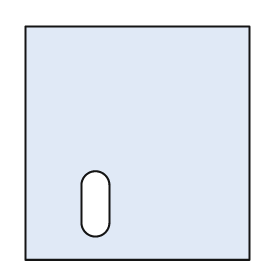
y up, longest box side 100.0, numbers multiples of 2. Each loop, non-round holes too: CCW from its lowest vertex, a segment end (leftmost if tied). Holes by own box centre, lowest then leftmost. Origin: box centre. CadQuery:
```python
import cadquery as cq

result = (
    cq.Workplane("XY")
    .moveTo(-48.0, -50.0)
    .lineTo(48.0, -50.0)
    .lineTo(48.0, 50.0)
    .lineTo(-48.0, 50.0)
    .close()
    .moveTo(-24.0, -34.0)
    .threePointArc((-18.0, -40.0), (-12.0, -34.0))
    .lineTo(-12.0, -18.0)
    .threePointArc((-18.0, -12.0), (-24.0, -18.0))
    .close()
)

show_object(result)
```